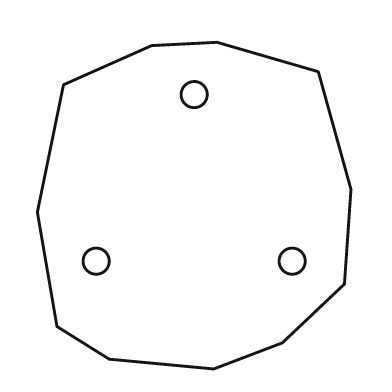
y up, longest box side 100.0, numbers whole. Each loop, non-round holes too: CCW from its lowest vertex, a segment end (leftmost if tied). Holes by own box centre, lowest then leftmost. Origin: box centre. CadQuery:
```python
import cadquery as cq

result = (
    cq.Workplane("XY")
    .moveTo(6.0, -50.0)
    .lineTo(27.0, -42.0)
    .lineTo(46.0, -24.0)
    .lineTo(48.0, 5.0)
    .lineTo(38.0, 41.0)
    .lineTo(7.0, 50.0)
    .lineTo(-13.0, 49.0)
    .lineTo(-40.0, 37.0)
    .lineTo(-48.0, -2.0)
    .lineTo(-42.0, -37.0)
    .lineTo(-26.0, -47.0)
    .close()
    .moveTo(-30.0, -17.0)
    .circle(4.0)
    .moveTo(30.0, -17.0)
    .circle(4.0)
    .moveTo(0.0, 34.0)
    .circle(4.0)
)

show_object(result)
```